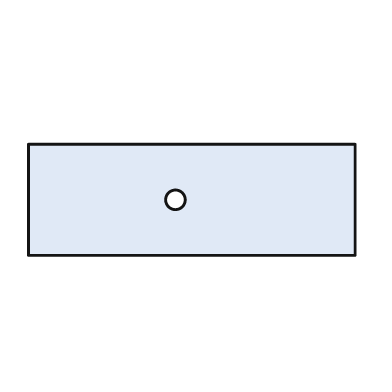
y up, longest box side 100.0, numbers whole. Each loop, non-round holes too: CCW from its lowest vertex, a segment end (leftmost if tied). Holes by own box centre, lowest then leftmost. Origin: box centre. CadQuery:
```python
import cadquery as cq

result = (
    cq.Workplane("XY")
    .moveTo(-50.0, -17.0)
    .lineTo(50.0, -17.0)
    .lineTo(50.0, 17.0)
    .lineTo(-50.0, 17.0)
    .close()
    .moveTo(-5.0, 0.0)
    .circle(3.0)
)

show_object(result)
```